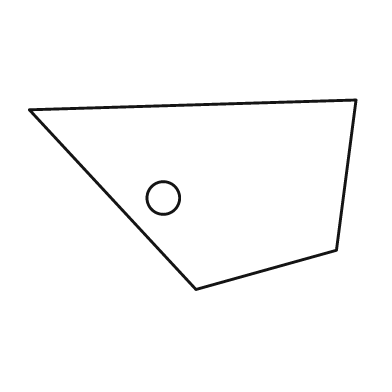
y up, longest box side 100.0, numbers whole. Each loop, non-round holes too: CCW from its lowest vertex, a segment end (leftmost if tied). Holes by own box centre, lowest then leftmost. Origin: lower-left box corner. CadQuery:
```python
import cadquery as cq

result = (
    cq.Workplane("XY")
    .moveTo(51.0, 0.0)
    .lineTo(94.0, 12.0)
    .lineTo(100.0, 58.0)
    .lineTo(0.0, 55.0)
    .close()
    .moveTo(41.0, 28.0)
    .circle(5.0)
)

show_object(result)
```